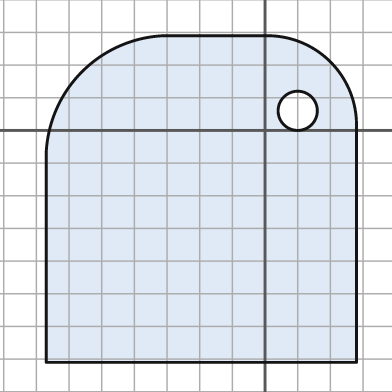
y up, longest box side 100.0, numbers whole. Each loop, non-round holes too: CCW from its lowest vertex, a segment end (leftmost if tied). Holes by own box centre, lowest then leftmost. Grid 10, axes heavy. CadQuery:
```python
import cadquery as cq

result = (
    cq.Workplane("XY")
    .moveTo(-67.0, -71.0)
    .lineTo(28.0, -71.0)
    .lineTo(28.0, 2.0)
    .threePointArc((20.0, 21.0), (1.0, 29.0))
    .lineTo(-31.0, 29.0)
    .threePointArc((-56.0, 18.0), (-67.0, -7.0))
    .close()
    .moveTo(10.0, 6.0)
    .circle(6.0)
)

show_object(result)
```